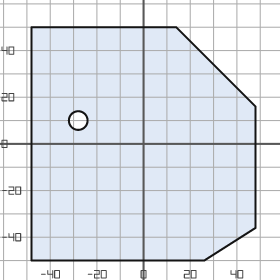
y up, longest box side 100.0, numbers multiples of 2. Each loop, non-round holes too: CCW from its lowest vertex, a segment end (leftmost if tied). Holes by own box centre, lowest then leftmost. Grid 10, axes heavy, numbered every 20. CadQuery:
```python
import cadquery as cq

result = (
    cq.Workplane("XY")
    .moveTo(-48.0, -50.0)
    .lineTo(26.0, -50.0)
    .lineTo(48.0, -36.0)
    .lineTo(48.0, 16.0)
    .lineTo(14.0, 50.0)
    .lineTo(-48.0, 50.0)
    .close()
    .moveTo(-28.0, 10.0)
    .circle(4.0)
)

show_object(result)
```